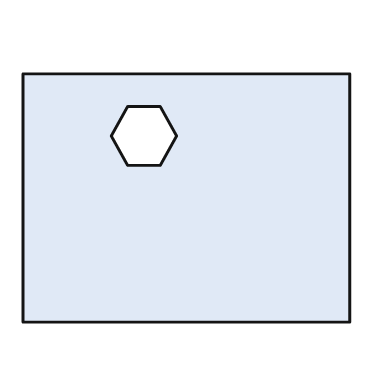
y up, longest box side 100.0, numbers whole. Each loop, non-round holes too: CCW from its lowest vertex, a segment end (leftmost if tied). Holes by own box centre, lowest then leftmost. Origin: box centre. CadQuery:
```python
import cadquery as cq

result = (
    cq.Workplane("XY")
    .moveTo(-50.0, -38.0)
    .lineTo(50.0, -38.0)
    .lineTo(50.0, 38.0)
    .lineTo(-50.0, 38.0)
    .close()
    .moveTo(-18.0, 10.0)
    .lineTo(-8.0, 10.0)
    .lineTo(-3.0, 19.0)
    .lineTo(-8.0, 28.0)
    .lineTo(-18.0, 28.0)
    .lineTo(-23.0, 19.0)
    .close()
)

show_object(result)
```